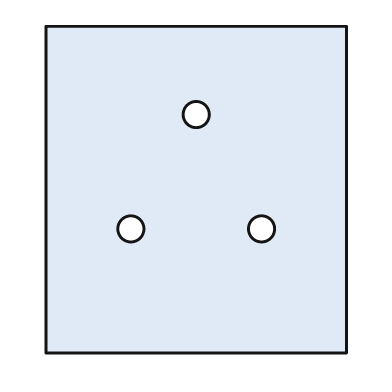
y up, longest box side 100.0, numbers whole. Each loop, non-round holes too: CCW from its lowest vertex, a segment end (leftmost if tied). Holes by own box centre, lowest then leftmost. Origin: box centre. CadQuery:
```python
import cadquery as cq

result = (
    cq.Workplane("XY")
    .moveTo(-46.0, -50.0)
    .lineTo(46.0, -50.0)
    .lineTo(46.0, 50.0)
    .lineTo(-46.0, 50.0)
    .close()
    .moveTo(-20.0, -12.0)
    .circle(4.0)
    .moveTo(20.0, -12.0)
    .circle(4.0)
    .moveTo(0.0, 23.0)
    .circle(4.0)
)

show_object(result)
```